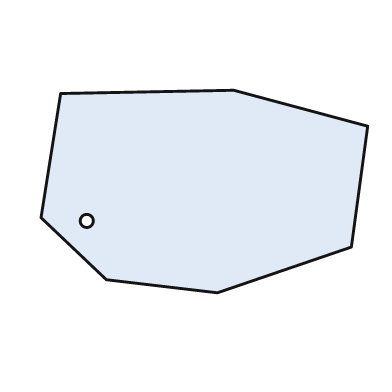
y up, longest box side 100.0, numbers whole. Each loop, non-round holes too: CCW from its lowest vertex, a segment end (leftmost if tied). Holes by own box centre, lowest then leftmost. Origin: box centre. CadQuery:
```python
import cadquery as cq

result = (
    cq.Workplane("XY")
    .moveTo(4.0, -31.0)
    .lineTo(45.0, -17.0)
    .lineTo(50.0, 20.0)
    .lineTo(9.0, 31.0)
    .lineTo(-44.0, 30.0)
    .lineTo(-50.0, -8.0)
    .lineTo(-30.0, -27.0)
    .close()
    .moveTo(-36.0, -9.0)
    .circle(2.0)
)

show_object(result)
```